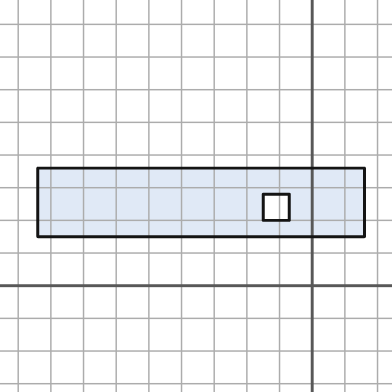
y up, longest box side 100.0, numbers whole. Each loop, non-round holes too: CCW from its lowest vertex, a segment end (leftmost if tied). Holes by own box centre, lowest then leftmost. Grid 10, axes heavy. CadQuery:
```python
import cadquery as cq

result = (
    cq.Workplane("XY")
    .moveTo(-84.0, 15.0)
    .lineTo(16.0, 15.0)
    .lineTo(16.0, 36.0)
    .lineTo(-84.0, 36.0)
    .close()
    .moveTo(-15.0, 20.0)
    .lineTo(-7.0, 20.0)
    .lineTo(-7.0, 28.0)
    .lineTo(-15.0, 28.0)
    .close()
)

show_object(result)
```